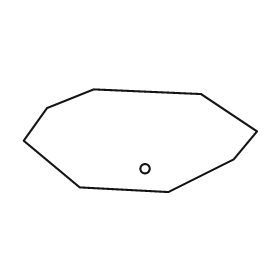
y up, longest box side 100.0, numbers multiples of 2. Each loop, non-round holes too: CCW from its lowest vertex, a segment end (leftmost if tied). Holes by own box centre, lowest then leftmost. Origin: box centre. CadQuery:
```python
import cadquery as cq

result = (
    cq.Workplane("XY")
    .moveTo(12.0, -22.0)
    .lineTo(40.0, -8.0)
    .lineTo(50.0, 4.0)
    .lineTo(26.0, 20.0)
    .lineTo(-20.0, 22.0)
    .lineTo(-40.0, 14.0)
    .lineTo(-50.0, 0.0)
    .lineTo(-26.0, -20.0)
    .close()
    .moveTo(2.0, -12.0)
    .circle(2.0)
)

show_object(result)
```